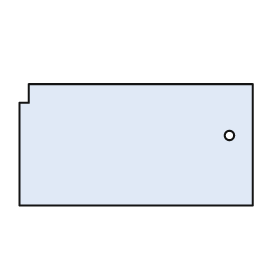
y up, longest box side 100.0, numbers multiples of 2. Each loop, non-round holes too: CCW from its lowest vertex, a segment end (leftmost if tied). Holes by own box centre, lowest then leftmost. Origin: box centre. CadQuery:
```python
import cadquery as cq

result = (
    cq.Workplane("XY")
    .moveTo(-50.0, -26.0)
    .lineTo(50.0, -26.0)
    .lineTo(50.0, 26.0)
    .lineTo(-46.0, 26.0)
    .lineTo(-46.0, 18.0)
    .lineTo(-50.0, 18.0)
    .close()
    .moveTo(40.0, 4.0)
    .circle(2.0)
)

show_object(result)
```